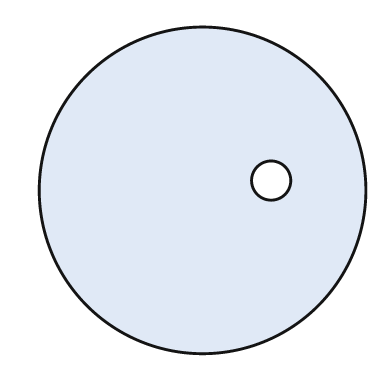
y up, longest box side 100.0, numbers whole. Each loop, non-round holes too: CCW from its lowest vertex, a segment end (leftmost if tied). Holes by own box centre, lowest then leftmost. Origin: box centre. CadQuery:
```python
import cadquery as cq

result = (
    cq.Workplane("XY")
    .moveTo(0.0, 0.0)
    .circle(50.0)
    .moveTo(21.0, 3.0)
    .circle(6.0)
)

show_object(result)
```